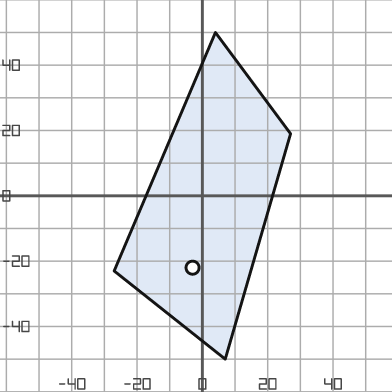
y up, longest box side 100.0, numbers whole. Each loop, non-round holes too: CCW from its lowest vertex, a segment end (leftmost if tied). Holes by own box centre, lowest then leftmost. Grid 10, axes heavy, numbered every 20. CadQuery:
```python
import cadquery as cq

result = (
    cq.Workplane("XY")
    .moveTo(7.0, -50.0)
    .lineTo(27.0, 19.0)
    .lineTo(4.0, 50.0)
    .lineTo(-27.0, -23.0)
    .close()
    .moveTo(-3.0, -22.0)
    .circle(2.0)
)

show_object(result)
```